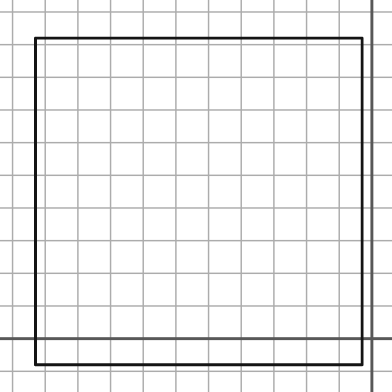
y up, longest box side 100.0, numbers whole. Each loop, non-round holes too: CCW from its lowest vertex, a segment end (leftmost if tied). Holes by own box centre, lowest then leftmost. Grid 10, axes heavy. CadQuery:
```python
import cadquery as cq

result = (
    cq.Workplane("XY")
    .moveTo(-103.0, -8.0)
    .lineTo(-3.0, -8.0)
    .lineTo(-3.0, 92.0)
    .lineTo(-103.0, 92.0)
    .close()
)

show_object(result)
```